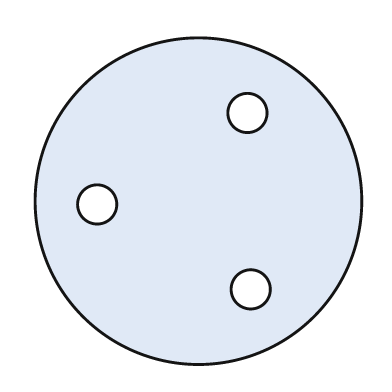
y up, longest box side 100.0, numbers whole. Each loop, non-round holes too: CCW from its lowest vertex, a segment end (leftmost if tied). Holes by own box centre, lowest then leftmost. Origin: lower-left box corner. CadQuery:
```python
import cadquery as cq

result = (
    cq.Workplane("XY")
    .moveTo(50.0, 50.0)
    .circle(50.0)
    .moveTo(66.0, 23.0)
    .circle(6.0)
    .moveTo(19.0, 49.0)
    .circle(6.0)
    .moveTo(65.0, 77.0)
    .circle(6.0)
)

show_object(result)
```